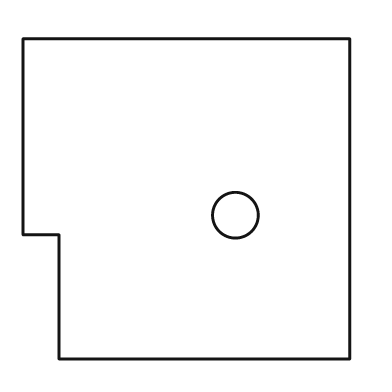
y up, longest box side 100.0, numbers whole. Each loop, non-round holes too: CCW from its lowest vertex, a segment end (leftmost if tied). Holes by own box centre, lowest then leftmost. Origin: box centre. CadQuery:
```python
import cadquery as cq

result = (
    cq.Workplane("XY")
    .moveTo(-39.0, -49.0)
    .lineTo(50.0, -49.0)
    .lineTo(50.0, 49.0)
    .lineTo(-50.0, 49.0)
    .lineTo(-50.0, -11.0)
    .lineTo(-39.0, -11.0)
    .close()
    .moveTo(15.0, -5.0)
    .circle(7.0)
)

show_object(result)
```